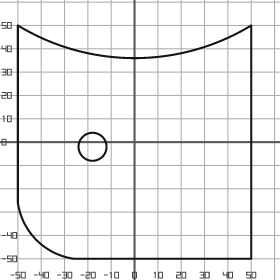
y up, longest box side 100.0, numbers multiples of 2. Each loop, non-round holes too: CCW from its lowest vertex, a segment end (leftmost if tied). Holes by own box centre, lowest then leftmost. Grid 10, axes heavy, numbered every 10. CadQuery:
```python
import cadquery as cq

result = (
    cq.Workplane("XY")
    .moveTo(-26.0, -50.0)
    .lineTo(50.0, -50.0)
    .lineTo(50.0, 50.0)
    .threePointArc((0.0, 36.0), (-50.0, 50.0))
    .lineTo(-50.0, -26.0)
    .threePointArc((-42.0, -42.0), (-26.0, -50.0))
    .close()
    .moveTo(-18.0, -2.0)
    .circle(6.0)
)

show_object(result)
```